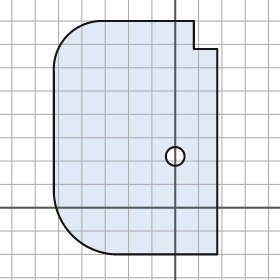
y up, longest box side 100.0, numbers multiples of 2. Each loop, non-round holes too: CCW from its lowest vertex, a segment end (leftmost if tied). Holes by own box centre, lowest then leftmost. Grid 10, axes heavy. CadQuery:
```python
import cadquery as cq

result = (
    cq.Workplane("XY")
    .moveTo(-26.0, -20.0)
    .lineTo(18.0, -20.0)
    .lineTo(18.0, 68.0)
    .lineTo(8.0, 68.0)
    .lineTo(8.0, 80.0)
    .lineTo(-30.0, 80.0)
    .threePointArc((-46.0, 74.0), (-52.0, 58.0))
    .lineTo(-52.0, 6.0)
    .threePointArc((-44.0, -12.0), (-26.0, -20.0))
    .close()
    .moveTo(0.0, 22.0)
    .circle(4.0)
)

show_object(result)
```